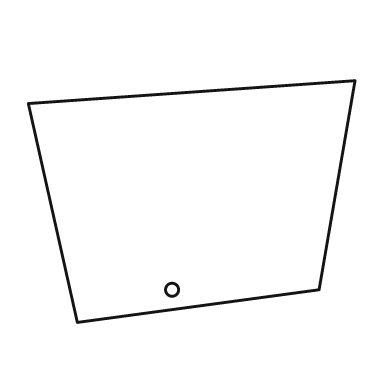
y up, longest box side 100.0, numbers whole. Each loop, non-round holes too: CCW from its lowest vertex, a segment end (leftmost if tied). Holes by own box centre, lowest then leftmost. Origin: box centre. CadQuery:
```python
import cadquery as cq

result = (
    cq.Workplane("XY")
    .moveTo(-35.0, -37.0)
    .lineTo(39.0, -27.0)
    .lineTo(50.0, 37.0)
    .lineTo(-50.0, 30.0)
    .close()
    .moveTo(-6.0, -27.0)
    .circle(2.0)
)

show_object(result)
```